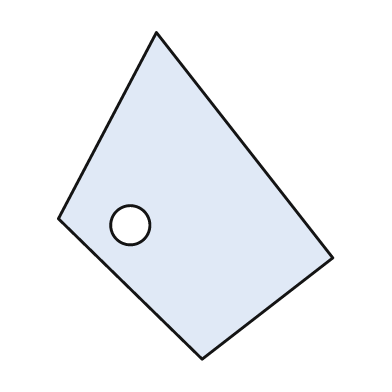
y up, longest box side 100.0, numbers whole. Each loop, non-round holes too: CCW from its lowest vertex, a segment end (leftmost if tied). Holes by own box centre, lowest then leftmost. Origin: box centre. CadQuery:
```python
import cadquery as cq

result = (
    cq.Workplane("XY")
    .moveTo(2.0, -50.0)
    .lineTo(42.0, -19.0)
    .lineTo(-12.0, 50.0)
    .lineTo(-42.0, -7.0)
    .close()
    .moveTo(-20.0, -9.0)
    .circle(6.0)
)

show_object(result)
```